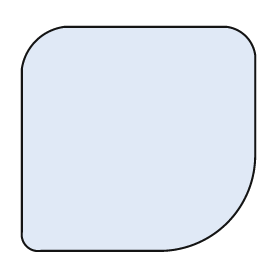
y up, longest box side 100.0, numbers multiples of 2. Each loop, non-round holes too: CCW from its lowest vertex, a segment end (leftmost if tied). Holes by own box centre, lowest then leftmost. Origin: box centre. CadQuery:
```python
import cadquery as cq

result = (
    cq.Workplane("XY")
    .moveTo(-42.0, -48.0)
    .lineTo(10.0, -48.0)
    .threePointArc((38.0, -36.0), (50.0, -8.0))
    .lineTo(50.0, 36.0)
    .threePointArc((46.0, 44.0), (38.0, 48.0))
    .lineTo(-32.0, 48.0)
    .threePointArc((-44.0, 42.0), (-50.0, 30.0))
    .lineTo(-50.0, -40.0)
    .threePointArc((-48.0, -46.0), (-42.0, -48.0))
    .close()
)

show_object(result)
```